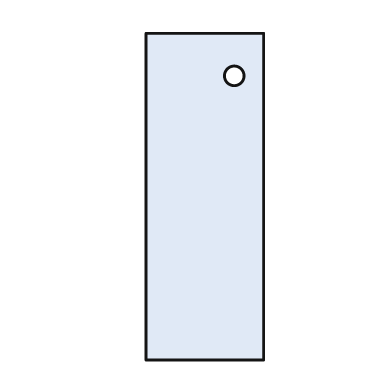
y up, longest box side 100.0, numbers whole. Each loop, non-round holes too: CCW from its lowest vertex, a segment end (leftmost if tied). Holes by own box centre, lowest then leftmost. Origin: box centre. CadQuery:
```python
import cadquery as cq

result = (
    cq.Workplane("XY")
    .moveTo(-18.0, -50.0)
    .lineTo(18.0, -50.0)
    .lineTo(18.0, 50.0)
    .lineTo(-18.0, 50.0)
    .close()
    .moveTo(9.0, 37.0)
    .circle(3.0)
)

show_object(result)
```